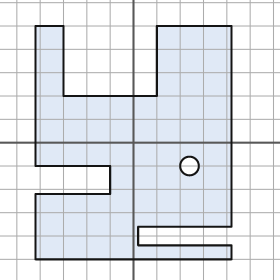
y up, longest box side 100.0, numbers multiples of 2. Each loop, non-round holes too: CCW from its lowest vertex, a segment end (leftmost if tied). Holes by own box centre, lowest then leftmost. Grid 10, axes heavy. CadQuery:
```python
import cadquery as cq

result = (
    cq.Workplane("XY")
    .moveTo(-42.0, -50.0)
    .lineTo(42.0, -50.0)
    .lineTo(42.0, -44.0)
    .lineTo(2.0, -44.0)
    .lineTo(2.0, -36.0)
    .lineTo(42.0, -36.0)
    .lineTo(42.0, 50.0)
    .lineTo(10.0, 50.0)
    .lineTo(10.0, 20.0)
    .lineTo(-30.0, 20.0)
    .lineTo(-30.0, 50.0)
    .lineTo(-42.0, 50.0)
    .lineTo(-42.0, -10.0)
    .lineTo(-10.0, -10.0)
    .lineTo(-10.0, -22.0)
    .lineTo(-42.0, -22.0)
    .close()
    .moveTo(24.0, -10.0)
    .circle(4.0)
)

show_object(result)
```